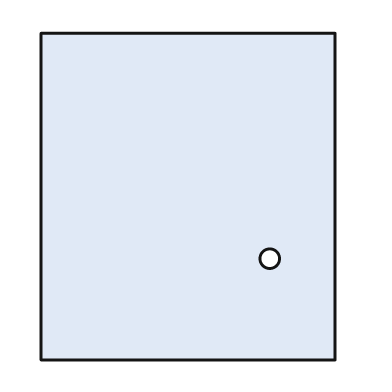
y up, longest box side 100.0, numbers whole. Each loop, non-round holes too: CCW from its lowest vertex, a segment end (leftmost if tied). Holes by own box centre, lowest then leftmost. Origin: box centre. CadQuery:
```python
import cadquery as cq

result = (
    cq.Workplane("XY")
    .moveTo(-45.0, -50.0)
    .lineTo(45.0, -50.0)
    .lineTo(45.0, 50.0)
    .lineTo(-45.0, 50.0)
    .close()
    .moveTo(25.0, -19.0)
    .circle(3.0)
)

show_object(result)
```